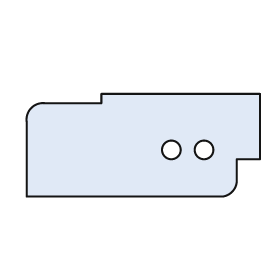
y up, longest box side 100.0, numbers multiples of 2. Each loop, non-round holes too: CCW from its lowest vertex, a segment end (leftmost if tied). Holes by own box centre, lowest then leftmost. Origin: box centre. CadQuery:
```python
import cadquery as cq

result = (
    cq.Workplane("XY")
    .moveTo(-50.0, -22.0)
    .lineTo(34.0, -22.0)
    .threePointArc((38.0, -20.0), (40.0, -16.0))
    .lineTo(40.0, -6.0)
    .lineTo(50.0, -6.0)
    .lineTo(50.0, 22.0)
    .lineTo(-18.0, 22.0)
    .lineTo(-18.0, 18.0)
    .lineTo(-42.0, 18.0)
    .threePointArc((-48.0, 16.0), (-50.0, 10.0))
    .close()
    .moveTo(12.0, -2.0)
    .circle(4.0)
    .moveTo(26.0, -2.0)
    .circle(4.0)
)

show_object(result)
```